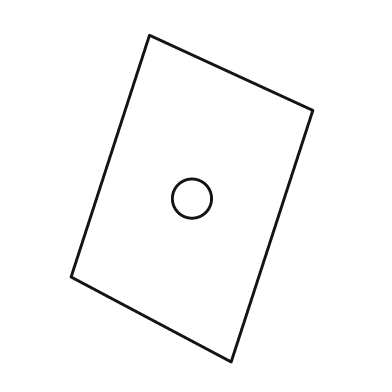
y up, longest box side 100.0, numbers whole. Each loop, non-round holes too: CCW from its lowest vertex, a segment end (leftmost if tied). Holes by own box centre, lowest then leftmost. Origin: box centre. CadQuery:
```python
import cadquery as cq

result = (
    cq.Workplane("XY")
    .moveTo(12.0, -50.0)
    .lineTo(37.0, 27.0)
    .lineTo(-13.0, 50.0)
    .lineTo(-37.0, -24.0)
    .close()
    .moveTo(0.0, 0.0)
    .circle(6.0)
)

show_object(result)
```